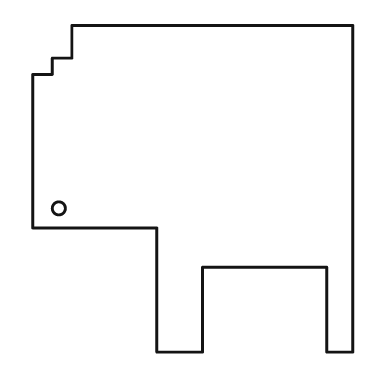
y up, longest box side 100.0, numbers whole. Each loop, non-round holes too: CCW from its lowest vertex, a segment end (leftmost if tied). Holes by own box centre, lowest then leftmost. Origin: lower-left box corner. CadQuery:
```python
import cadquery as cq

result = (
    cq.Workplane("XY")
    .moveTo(38.0, 0.0)
    .lineTo(52.0, 0.0)
    .lineTo(52.0, 26.0)
    .lineTo(90.0, 26.0)
    .lineTo(90.0, 0.0)
    .lineTo(98.0, 0.0)
    .lineTo(98.0, 100.0)
    .lineTo(12.0, 100.0)
    .lineTo(12.0, 90.0)
    .lineTo(6.0, 90.0)
    .lineTo(6.0, 85.0)
    .lineTo(0.0, 85.0)
    .lineTo(0.0, 38.0)
    .lineTo(38.0, 38.0)
    .close()
    .moveTo(8.0, 44.0)
    .circle(2.0)
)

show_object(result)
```